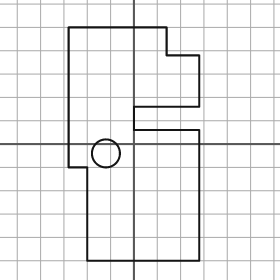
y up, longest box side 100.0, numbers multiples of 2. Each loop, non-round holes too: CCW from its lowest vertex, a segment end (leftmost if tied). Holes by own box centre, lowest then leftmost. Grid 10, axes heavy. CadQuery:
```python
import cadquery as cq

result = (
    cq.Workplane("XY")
    .moveTo(-20.0, -50.0)
    .lineTo(28.0, -50.0)
    .lineTo(28.0, 6.0)
    .lineTo(0.0, 6.0)
    .lineTo(0.0, 16.0)
    .lineTo(28.0, 16.0)
    .lineTo(28.0, 38.0)
    .lineTo(14.0, 38.0)
    .lineTo(14.0, 50.0)
    .lineTo(-28.0, 50.0)
    .lineTo(-28.0, -10.0)
    .lineTo(-20.0, -10.0)
    .close()
    .moveTo(-12.0, -4.0)
    .circle(6.0)
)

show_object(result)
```